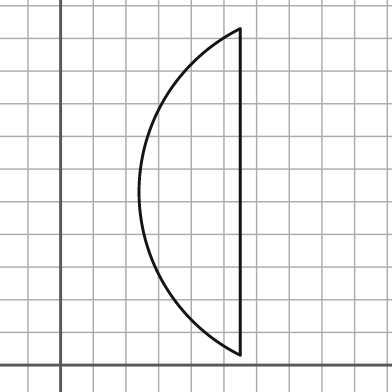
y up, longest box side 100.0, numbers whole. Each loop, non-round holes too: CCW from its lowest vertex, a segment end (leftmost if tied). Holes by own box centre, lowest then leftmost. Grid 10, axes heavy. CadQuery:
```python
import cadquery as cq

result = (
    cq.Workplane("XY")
    .moveTo(55.0, 3.0)
    .lineTo(55.0, 103.0)
    .threePointArc((24.0, 53.0), (55.0, 3.0))
    .close()
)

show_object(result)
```